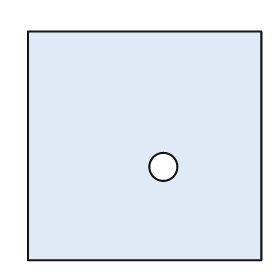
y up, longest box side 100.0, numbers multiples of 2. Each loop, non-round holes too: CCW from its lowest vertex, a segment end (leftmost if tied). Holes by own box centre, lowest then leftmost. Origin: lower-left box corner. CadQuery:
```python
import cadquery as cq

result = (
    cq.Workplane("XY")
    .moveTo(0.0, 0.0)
    .lineTo(100.0, 0.0)
    .lineTo(100.0, 98.0)
    .lineTo(0.0, 98.0)
    .close()
    .moveTo(58.0, 40.0)
    .circle(6.0)
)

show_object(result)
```